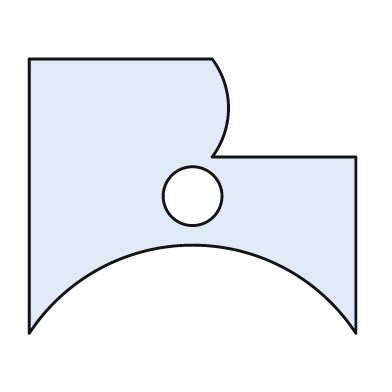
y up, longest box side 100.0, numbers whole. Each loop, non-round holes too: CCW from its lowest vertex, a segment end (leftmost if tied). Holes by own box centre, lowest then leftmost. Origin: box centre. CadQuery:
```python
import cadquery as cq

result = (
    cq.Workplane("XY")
    .moveTo(-50.0, -42.0)
    .threePointArc((0.0, -15.0), (50.0, -42.0))
    .lineTo(50.0, 12.0)
    .lineTo(6.0, 12.0)
    .threePointArc((11.0, 27.0), (6.0, 42.0))
    .lineTo(-50.0, 42.0)
    .close()
    .moveTo(0.0, 0.0)
    .circle(9.0)
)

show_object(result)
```